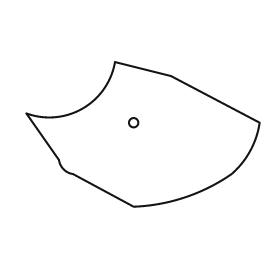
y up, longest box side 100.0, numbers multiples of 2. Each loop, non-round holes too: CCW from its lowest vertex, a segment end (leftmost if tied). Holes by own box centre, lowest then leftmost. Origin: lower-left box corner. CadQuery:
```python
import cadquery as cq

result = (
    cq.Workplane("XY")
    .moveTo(46.0, 0.0)
    .threePointArc((68.0, 4.0), (88.0, 14.0))
    .threePointArc((96.0, 24.0), (100.0, 36.0))
    .lineTo(62.0, 56.0)
    .lineTo(38.0, 62.0)
    .threePointArc((24.0, 42.0), (0.0, 40.0))
    .lineTo(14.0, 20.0)
    .threePointArc((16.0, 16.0), (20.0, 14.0))
    .close()
    .moveTo(46.0, 36.0)
    .circle(2.0)
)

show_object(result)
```